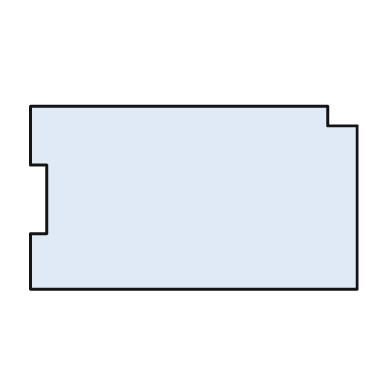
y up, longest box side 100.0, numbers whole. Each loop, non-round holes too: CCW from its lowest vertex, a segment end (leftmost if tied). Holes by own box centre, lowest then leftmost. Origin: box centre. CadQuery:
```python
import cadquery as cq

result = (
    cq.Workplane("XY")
    .moveTo(-50.0, -28.0)
    .lineTo(50.0, -28.0)
    .lineTo(50.0, 22.0)
    .lineTo(41.0, 22.0)
    .lineTo(41.0, 28.0)
    .lineTo(-50.0, 28.0)
    .lineTo(-50.0, 10.0)
    .lineTo(-45.0, 10.0)
    .lineTo(-45.0, -11.0)
    .lineTo(-50.0, -11.0)
    .close()
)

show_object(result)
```